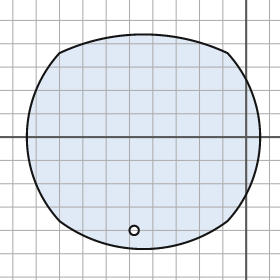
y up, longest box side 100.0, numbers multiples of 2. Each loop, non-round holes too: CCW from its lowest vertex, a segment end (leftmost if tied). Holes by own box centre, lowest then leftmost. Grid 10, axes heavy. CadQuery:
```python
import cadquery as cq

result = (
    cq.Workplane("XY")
    .moveTo(-80.0, -36.0)
    .threePointArc((-44.0, -48.0), (-8.0, -36.0))
    .threePointArc((6.0, 0.0), (-8.0, 36.0))
    .threePointArc((-44.0, 44.0), (-80.0, 36.0))
    .threePointArc((-94.0, 0.0), (-80.0, -36.0))
    .close()
    .moveTo(-48.0, -40.0)
    .circle(2.0)
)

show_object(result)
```